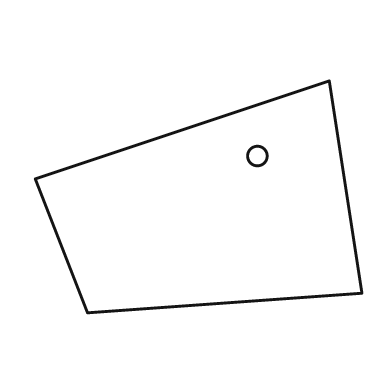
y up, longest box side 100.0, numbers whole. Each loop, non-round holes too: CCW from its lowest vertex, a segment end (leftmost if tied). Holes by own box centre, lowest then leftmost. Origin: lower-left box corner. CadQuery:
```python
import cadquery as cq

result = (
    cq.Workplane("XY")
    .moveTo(16.0, 0.0)
    .lineTo(100.0, 6.0)
    .lineTo(90.0, 71.0)
    .lineTo(0.0, 41.0)
    .close()
    .moveTo(68.0, 48.0)
    .circle(3.0)
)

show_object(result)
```